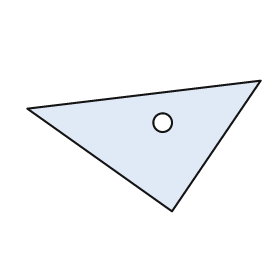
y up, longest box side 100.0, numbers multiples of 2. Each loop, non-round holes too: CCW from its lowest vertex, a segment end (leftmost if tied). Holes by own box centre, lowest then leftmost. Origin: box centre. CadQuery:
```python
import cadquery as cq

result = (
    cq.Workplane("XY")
    .moveTo(12.0, -28.0)
    .lineTo(50.0, 28.0)
    .lineTo(-50.0, 16.0)
    .close()
    .moveTo(8.0, 10.0)
    .circle(4.0)
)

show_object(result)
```